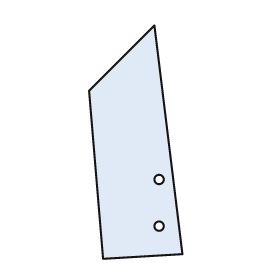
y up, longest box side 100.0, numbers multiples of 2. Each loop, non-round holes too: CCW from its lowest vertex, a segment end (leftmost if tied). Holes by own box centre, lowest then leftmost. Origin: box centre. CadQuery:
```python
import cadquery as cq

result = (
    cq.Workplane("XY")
    .moveTo(-14.0, -50.0)
    .lineTo(20.0, -48.0)
    .lineTo(8.0, 50.0)
    .lineTo(-20.0, 22.0)
    .close()
    .moveTo(10.0, -36.0)
    .circle(2.0)
    .moveTo(10.0, -16.0)
    .circle(2.0)
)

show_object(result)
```